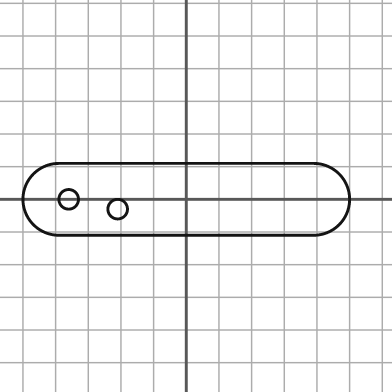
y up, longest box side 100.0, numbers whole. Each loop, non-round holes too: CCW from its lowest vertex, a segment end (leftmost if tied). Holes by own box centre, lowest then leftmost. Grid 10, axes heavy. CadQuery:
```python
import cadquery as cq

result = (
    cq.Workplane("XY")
    .moveTo(-39.0, -11.0)
    .lineTo(39.0, -11.0)
    .threePointArc((50.0, 0.0), (39.0, 11.0))
    .lineTo(-39.0, 11.0)
    .threePointArc((-50.0, 0.0), (-39.0, -11.0))
    .close()
    .moveTo(-21.0, -3.0)
    .circle(3.0)
    .moveTo(-36.0, 0.0)
    .circle(3.0)
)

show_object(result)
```